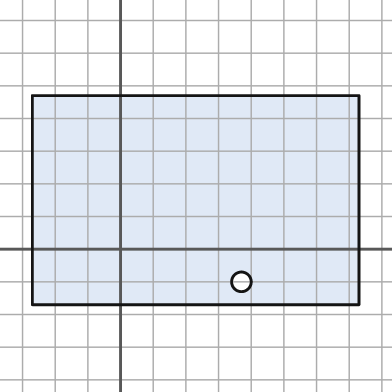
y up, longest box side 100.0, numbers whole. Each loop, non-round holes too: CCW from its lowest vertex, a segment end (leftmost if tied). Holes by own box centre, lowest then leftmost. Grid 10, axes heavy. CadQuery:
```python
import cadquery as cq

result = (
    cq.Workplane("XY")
    .moveTo(-27.0, -17.0)
    .lineTo(73.0, -17.0)
    .lineTo(73.0, 47.0)
    .lineTo(-27.0, 47.0)
    .close()
    .moveTo(37.0, -10.0)
    .circle(3.0)
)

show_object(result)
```